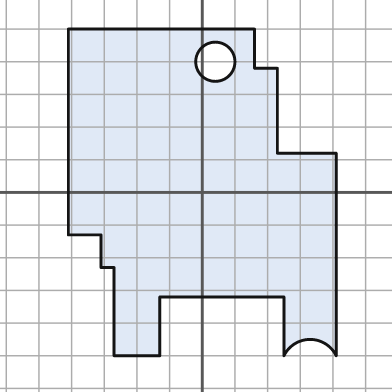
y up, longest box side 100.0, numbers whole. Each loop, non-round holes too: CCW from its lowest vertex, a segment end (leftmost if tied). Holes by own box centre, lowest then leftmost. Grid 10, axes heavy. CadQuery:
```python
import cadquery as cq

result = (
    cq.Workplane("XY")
    .moveTo(-27.0, -50.0)
    .lineTo(-13.0, -50.0)
    .lineTo(-13.0, -32.0)
    .lineTo(25.0, -32.0)
    .lineTo(25.0, -50.0)
    .threePointArc((33.0, -45.0), (41.0, -50.0))
    .lineTo(41.0, 12.0)
    .lineTo(23.0, 12.0)
    .lineTo(23.0, 38.0)
    .lineTo(16.0, 38.0)
    .lineTo(16.0, 50.0)
    .lineTo(-41.0, 50.0)
    .lineTo(-41.0, -13.0)
    .lineTo(-31.0, -13.0)
    .lineTo(-31.0, -23.0)
    .lineTo(-27.0, -23.0)
    .close()
    .moveTo(4.0, 40.0)
    .circle(6.0)
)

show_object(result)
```